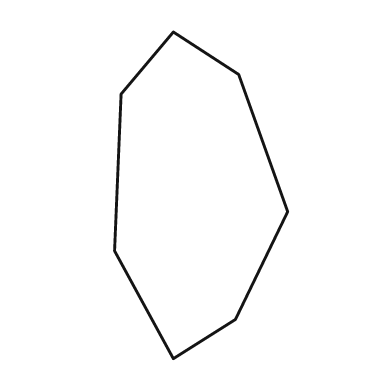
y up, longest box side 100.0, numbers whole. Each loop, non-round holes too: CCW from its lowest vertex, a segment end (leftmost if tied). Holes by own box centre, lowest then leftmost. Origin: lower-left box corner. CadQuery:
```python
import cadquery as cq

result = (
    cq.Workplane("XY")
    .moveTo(18.0, 0.0)
    .lineTo(37.0, 12.0)
    .lineTo(53.0, 45.0)
    .lineTo(38.0, 87.0)
    .lineTo(18.0, 100.0)
    .lineTo(2.0, 81.0)
    .lineTo(0.0, 33.0)
    .close()
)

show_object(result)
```